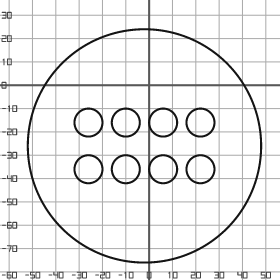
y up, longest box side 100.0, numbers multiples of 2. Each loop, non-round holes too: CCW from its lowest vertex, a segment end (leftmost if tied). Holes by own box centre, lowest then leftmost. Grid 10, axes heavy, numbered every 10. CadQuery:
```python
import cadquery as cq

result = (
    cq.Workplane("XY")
    .moveTo(-2.0, -26.0)
    .circle(50.0)
    .moveTo(-26.0, -36.0)
    .circle(6.0)
    .moveTo(-10.0, -36.0)
    .circle(6.0)
    .moveTo(6.0, -36.0)
    .circle(6.0)
    .moveTo(22.0, -36.0)
    .circle(6.0)
    .moveTo(-26.0, -16.0)
    .circle(6.0)
    .moveTo(-10.0, -16.0)
    .circle(6.0)
    .moveTo(6.0, -16.0)
    .circle(6.0)
    .moveTo(22.0, -16.0)
    .circle(6.0)
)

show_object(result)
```